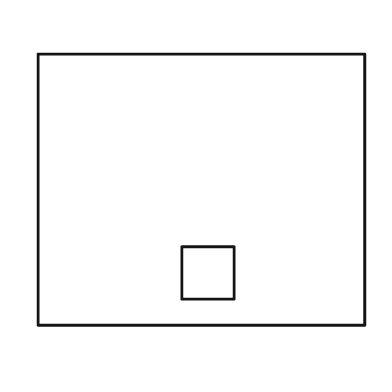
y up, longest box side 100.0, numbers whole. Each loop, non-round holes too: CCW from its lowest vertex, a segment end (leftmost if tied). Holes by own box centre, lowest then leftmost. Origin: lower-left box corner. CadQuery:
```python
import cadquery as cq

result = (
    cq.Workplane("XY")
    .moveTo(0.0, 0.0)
    .lineTo(100.0, 0.0)
    .lineTo(100.0, 83.0)
    .lineTo(0.0, 83.0)
    .close()
    .moveTo(44.0, 8.0)
    .lineTo(60.0, 8.0)
    .lineTo(60.0, 24.0)
    .lineTo(44.0, 24.0)
    .close()
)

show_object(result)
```